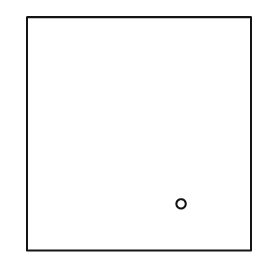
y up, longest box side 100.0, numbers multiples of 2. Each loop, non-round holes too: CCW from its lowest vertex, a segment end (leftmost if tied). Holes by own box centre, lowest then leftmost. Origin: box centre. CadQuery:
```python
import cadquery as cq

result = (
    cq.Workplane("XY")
    .moveTo(-48.0, -50.0)
    .lineTo(48.0, -50.0)
    .lineTo(48.0, 50.0)
    .lineTo(-48.0, 50.0)
    .close()
    .moveTo(18.0, -30.0)
    .circle(2.0)
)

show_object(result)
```